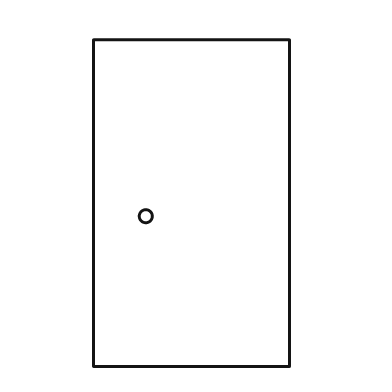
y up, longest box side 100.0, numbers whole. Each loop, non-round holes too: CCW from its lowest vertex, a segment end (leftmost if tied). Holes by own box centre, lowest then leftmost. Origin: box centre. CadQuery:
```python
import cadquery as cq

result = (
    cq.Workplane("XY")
    .moveTo(-30.0, -50.0)
    .lineTo(30.0, -50.0)
    .lineTo(30.0, 50.0)
    .lineTo(-30.0, 50.0)
    .close()
    .moveTo(-14.0, -4.0)
    .circle(2.0)
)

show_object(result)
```